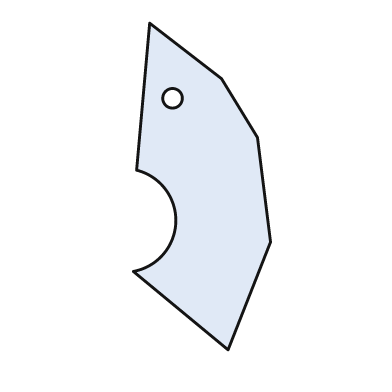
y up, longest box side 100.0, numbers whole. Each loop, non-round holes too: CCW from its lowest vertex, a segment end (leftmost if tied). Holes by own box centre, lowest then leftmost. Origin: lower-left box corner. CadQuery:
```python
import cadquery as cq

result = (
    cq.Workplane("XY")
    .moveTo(29.0, 0.0)
    .lineTo(42.0, 33.0)
    .lineTo(38.0, 65.0)
    .lineTo(27.0, 83.0)
    .lineTo(5.0, 100.0)
    .lineTo(1.0, 55.0)
    .threePointArc((13.0, 39.0), (0.0, 24.0))
    .close()
    .moveTo(12.0, 77.0)
    .circle(3.0)
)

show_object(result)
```